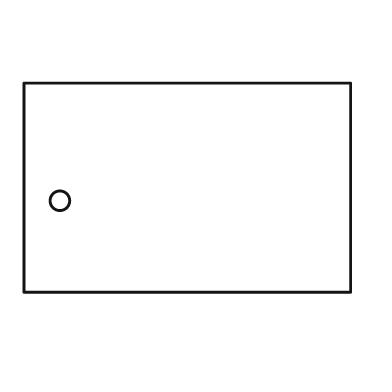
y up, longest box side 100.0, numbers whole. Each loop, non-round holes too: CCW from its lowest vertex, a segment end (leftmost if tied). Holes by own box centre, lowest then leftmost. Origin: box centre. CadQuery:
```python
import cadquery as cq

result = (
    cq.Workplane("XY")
    .moveTo(-50.0, -32.0)
    .lineTo(50.0, -32.0)
    .lineTo(50.0, 32.0)
    .lineTo(-50.0, 32.0)
    .close()
    .moveTo(-39.0, -4.0)
    .circle(3.0)
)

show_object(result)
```